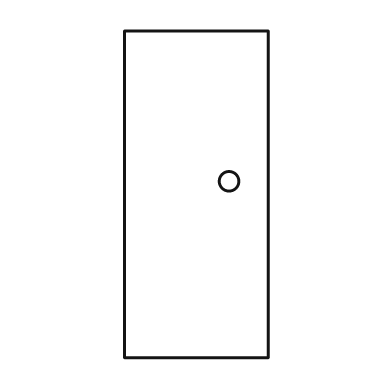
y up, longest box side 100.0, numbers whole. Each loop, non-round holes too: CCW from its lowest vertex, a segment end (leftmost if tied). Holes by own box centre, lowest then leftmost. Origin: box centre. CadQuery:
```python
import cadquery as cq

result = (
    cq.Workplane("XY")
    .moveTo(-22.0, -50.0)
    .lineTo(22.0, -50.0)
    .lineTo(22.0, 50.0)
    .lineTo(-22.0, 50.0)
    .close()
    .moveTo(10.0, 4.0)
    .circle(3.0)
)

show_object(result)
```